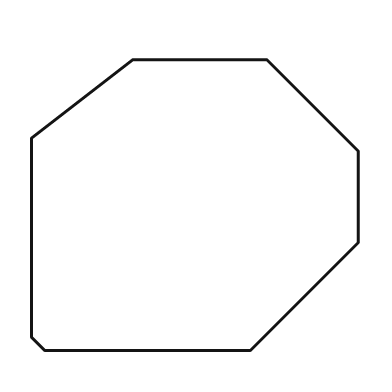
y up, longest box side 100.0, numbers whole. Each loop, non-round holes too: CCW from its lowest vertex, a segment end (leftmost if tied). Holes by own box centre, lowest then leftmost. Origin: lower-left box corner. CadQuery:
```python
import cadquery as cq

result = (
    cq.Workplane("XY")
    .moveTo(4.0, 0.0)
    .lineTo(67.0, 0.0)
    .lineTo(100.0, 33.0)
    .lineTo(100.0, 61.0)
    .lineTo(72.0, 89.0)
    .lineTo(31.0, 89.0)
    .lineTo(0.0, 65.0)
    .lineTo(0.0, 4.0)
    .close()
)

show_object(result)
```